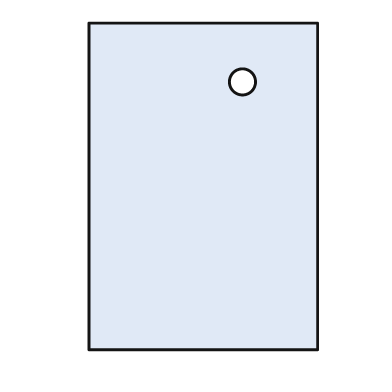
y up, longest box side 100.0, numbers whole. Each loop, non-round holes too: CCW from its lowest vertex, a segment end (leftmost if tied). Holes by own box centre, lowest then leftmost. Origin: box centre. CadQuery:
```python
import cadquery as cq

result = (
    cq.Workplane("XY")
    .moveTo(-35.0, -50.0)
    .lineTo(35.0, -50.0)
    .lineTo(35.0, 50.0)
    .lineTo(-35.0, 50.0)
    .close()
    .moveTo(12.0, 32.0)
    .circle(4.0)
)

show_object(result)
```